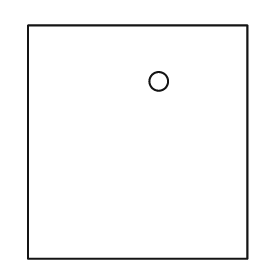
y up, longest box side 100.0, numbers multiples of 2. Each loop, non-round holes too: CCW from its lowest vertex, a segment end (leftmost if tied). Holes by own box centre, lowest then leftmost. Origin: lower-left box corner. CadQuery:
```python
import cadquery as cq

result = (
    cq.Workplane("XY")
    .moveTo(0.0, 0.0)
    .lineTo(94.0, 0.0)
    .lineTo(94.0, 100.0)
    .lineTo(0.0, 100.0)
    .close()
    .moveTo(56.0, 76.0)
    .circle(4.0)
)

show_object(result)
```